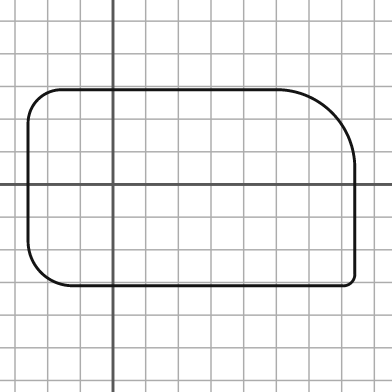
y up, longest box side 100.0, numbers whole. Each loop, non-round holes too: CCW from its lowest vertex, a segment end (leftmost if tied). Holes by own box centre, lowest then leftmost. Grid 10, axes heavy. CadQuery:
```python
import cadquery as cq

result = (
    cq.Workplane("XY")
    .moveTo(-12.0, -31.0)
    .lineTo(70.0, -31.0)
    .threePointArc((73.0, -30.0), (74.0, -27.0))
    .lineTo(74.0, 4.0)
    .threePointArc((67.0, 22.0), (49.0, 29.0))
    .lineTo(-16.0, 29.0)
    .threePointArc((-23.0, 26.0), (-26.0, 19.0))
    .lineTo(-26.0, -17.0)
    .threePointArc((-22.0, -27.0), (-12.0, -31.0))
    .close()
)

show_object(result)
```